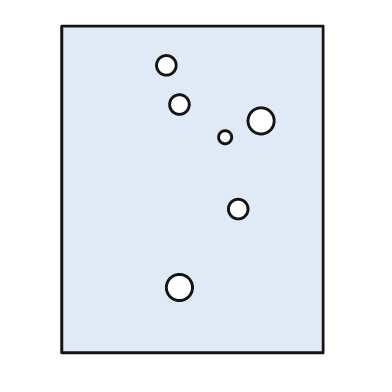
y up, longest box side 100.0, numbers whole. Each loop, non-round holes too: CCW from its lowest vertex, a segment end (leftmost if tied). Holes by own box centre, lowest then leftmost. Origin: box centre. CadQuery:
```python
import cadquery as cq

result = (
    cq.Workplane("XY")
    .moveTo(-40.0, -50.0)
    .lineTo(40.0, -50.0)
    .lineTo(40.0, 50.0)
    .lineTo(-40.0, 50.0)
    .close()
    .moveTo(-4.0, -30.0)
    .circle(4.0)
    .moveTo(14.0, -6.0)
    .circle(3.0)
    .moveTo(10.0, 16.0)
    .circle(2.0)
    .moveTo(21.0, 21.0)
    .circle(4.0)
    .moveTo(-4.0, 26.0)
    .circle(3.0)
    .moveTo(-8.0, 38.0)
    .circle(3.0)
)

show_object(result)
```